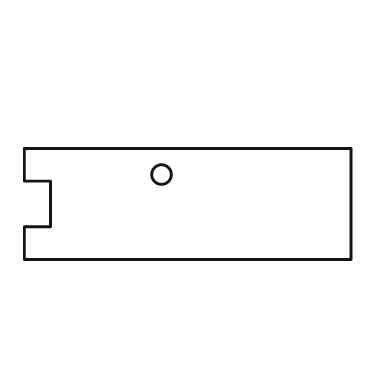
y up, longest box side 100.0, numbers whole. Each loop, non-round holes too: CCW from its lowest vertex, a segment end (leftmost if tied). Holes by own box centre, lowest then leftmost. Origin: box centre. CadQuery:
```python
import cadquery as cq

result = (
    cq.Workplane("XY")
    .moveTo(-50.0, -17.0)
    .lineTo(50.0, -17.0)
    .lineTo(50.0, 17.0)
    .lineTo(-50.0, 17.0)
    .lineTo(-50.0, 7.0)
    .lineTo(-42.0, 7.0)
    .lineTo(-42.0, -7.0)
    .lineTo(-50.0, -7.0)
    .close()
    .moveTo(-8.0, 9.0)
    .circle(3.0)
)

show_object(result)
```